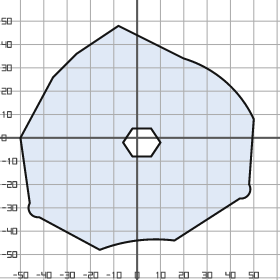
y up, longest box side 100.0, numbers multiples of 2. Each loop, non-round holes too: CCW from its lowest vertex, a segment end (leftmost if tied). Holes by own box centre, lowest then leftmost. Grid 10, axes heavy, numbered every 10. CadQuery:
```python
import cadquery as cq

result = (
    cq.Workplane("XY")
    .moveTo(-16.0, -48.0)
    .threePointArc((0.0, -44.0), (16.0, -44.0))
    .lineTo(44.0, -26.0)
    .threePointArc((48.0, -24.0), (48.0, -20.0))
    .lineTo(50.0, 8.0)
    .threePointArc((38.0, 24.0), (20.0, 34.0))
    .lineTo(-8.0, 48.0)
    .lineTo(-26.0, 36.0)
    .lineTo(-36.0, 26.0)
    .lineTo(-50.0, 0.0)
    .lineTo(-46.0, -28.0)
    .threePointArc((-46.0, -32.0), (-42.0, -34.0))
    .close()
    .moveTo(-2.0, -8.0)
    .lineTo(6.0, -8.0)
    .lineTo(10.0, -2.0)
    .lineTo(6.0, 4.0)
    .lineTo(-2.0, 4.0)
    .lineTo(-6.0, -2.0)
    .close()
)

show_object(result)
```